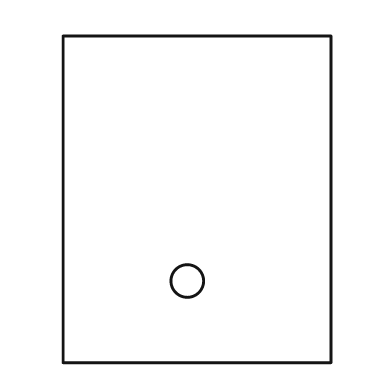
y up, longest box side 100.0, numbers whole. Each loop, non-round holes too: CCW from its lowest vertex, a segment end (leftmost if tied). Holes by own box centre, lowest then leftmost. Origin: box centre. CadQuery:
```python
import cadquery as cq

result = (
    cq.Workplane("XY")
    .moveTo(-41.0, -50.0)
    .lineTo(41.0, -50.0)
    .lineTo(41.0, 50.0)
    .lineTo(-41.0, 50.0)
    .close()
    .moveTo(-3.0, -25.0)
    .circle(5.0)
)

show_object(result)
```